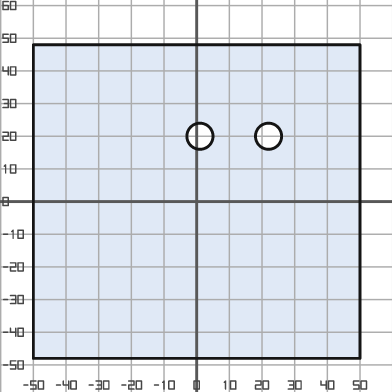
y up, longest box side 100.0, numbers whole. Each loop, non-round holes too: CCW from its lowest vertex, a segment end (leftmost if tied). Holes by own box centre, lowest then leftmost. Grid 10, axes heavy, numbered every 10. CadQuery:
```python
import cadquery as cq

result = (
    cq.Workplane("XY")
    .moveTo(-50.0, -48.0)
    .lineTo(50.0, -48.0)
    .lineTo(50.0, 48.0)
    .lineTo(-50.0, 48.0)
    .close()
    .moveTo(1.0, 20.0)
    .circle(4.0)
    .moveTo(22.0, 20.0)
    .circle(4.0)
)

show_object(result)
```